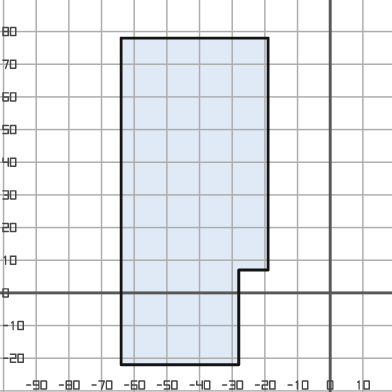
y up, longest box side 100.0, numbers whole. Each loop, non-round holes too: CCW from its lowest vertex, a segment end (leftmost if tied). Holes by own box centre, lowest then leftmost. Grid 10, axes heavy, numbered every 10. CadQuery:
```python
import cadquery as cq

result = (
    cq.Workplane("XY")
    .moveTo(-64.0, -22.0)
    .lineTo(-28.0, -22.0)
    .lineTo(-28.0, 7.0)
    .lineTo(-19.0, 7.0)
    .lineTo(-19.0, 78.0)
    .lineTo(-64.0, 78.0)
    .close()
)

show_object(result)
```